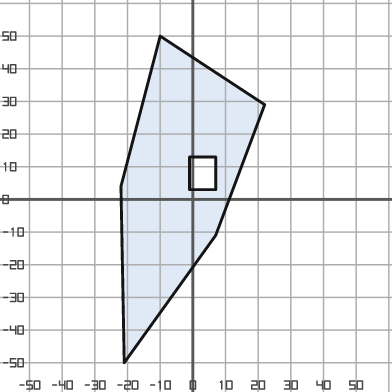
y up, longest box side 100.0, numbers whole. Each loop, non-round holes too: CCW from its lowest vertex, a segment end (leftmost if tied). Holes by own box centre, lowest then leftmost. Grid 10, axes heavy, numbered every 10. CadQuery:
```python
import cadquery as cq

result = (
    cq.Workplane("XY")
    .moveTo(-21.0, -50.0)
    .lineTo(7.0, -11.0)
    .lineTo(22.0, 29.0)
    .lineTo(-10.0, 50.0)
    .lineTo(-22.0, 4.0)
    .close()
    .moveTo(-1.0, 3.0)
    .lineTo(7.0, 3.0)
    .lineTo(7.0, 13.0)
    .lineTo(-1.0, 13.0)
    .close()
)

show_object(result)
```